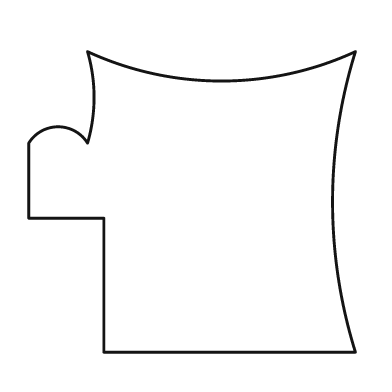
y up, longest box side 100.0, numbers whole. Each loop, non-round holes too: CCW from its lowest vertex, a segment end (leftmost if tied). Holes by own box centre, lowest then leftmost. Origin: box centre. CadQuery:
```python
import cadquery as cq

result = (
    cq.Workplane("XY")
    .moveTo(-27.0, -46.0)
    .lineTo(50.0, -46.0)
    .threePointArc((43.0, 0.0), (50.0, 46.0))
    .threePointArc((9.0, 37.0), (-32.0, 46.0))
    .threePointArc((-30.0, 32.0), (-32.0, 18.0))
    .threePointArc((-41.0, 23.0), (-50.0, 18.0))
    .lineTo(-50.0, -5.0)
    .lineTo(-27.0, -5.0)
    .close()
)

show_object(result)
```